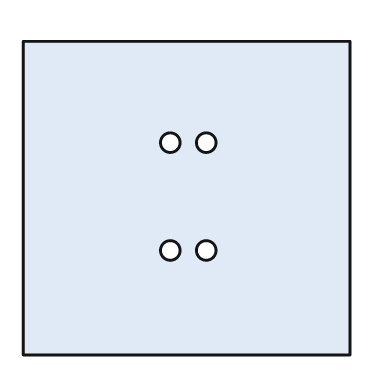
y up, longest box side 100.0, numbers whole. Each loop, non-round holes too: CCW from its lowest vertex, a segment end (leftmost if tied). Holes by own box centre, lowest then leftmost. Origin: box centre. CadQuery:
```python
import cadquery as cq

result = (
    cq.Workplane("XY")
    .moveTo(-50.0, -48.0)
    .lineTo(50.0, -48.0)
    .lineTo(50.0, 48.0)
    .lineTo(-50.0, 48.0)
    .close()
    .moveTo(-5.0, -16.0)
    .circle(3.0)
    .moveTo(6.0, -16.0)
    .circle(3.0)
    .moveTo(-5.0, 17.0)
    .circle(3.0)
    .moveTo(6.0, 17.0)
    .circle(3.0)
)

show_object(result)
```